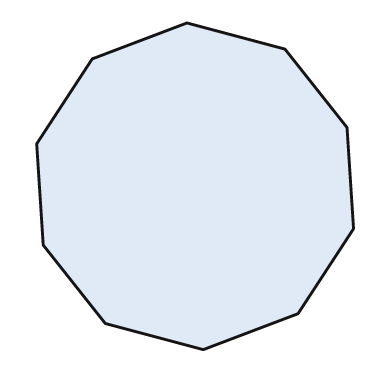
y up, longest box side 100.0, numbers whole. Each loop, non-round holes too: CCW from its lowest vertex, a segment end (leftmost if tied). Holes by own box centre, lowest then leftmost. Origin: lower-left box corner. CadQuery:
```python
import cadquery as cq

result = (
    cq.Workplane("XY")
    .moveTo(51.0, 0.0)
    .lineTo(80.0, 11.0)
    .lineTo(97.0, 37.0)
    .lineTo(95.0, 68.0)
    .lineTo(76.0, 92.0)
    .lineTo(46.0, 100.0)
    .lineTo(17.0, 89.0)
    .lineTo(0.0, 63.0)
    .lineTo(2.0, 32.0)
    .lineTo(21.0, 8.0)
    .close()
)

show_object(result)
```